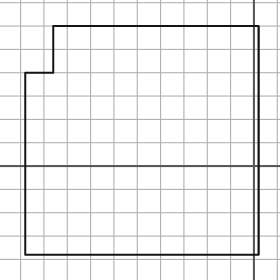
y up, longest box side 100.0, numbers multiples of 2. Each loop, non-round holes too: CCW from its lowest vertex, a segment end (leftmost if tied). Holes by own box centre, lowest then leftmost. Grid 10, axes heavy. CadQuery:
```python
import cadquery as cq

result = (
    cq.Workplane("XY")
    .moveTo(-98.0, -38.0)
    .lineTo(2.0, -38.0)
    .lineTo(2.0, 60.0)
    .lineTo(-86.0, 60.0)
    .lineTo(-86.0, 40.0)
    .lineTo(-98.0, 40.0)
    .close()
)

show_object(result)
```